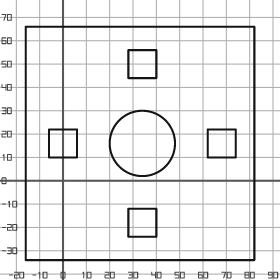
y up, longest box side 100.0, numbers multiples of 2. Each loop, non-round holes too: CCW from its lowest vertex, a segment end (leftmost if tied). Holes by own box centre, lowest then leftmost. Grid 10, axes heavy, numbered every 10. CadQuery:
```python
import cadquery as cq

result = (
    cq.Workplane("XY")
    .moveTo(-16.0, -34.0)
    .lineTo(82.0, -34.0)
    .lineTo(82.0, 66.0)
    .lineTo(-16.0, 66.0)
    .close()
    .moveTo(28.0, -24.0)
    .lineTo(40.0, -24.0)
    .lineTo(40.0, -12.0)
    .lineTo(28.0, -12.0)
    .close()
    .moveTo(-6.0, 10.0)
    .lineTo(6.0, 10.0)
    .lineTo(6.0, 22.0)
    .lineTo(-6.0, 22.0)
    .close()
    .moveTo(34.0, 16.0)
    .circle(14.0)
    .moveTo(62.0, 10.0)
    .lineTo(74.0, 10.0)
    .lineTo(74.0, 22.0)
    .lineTo(62.0, 22.0)
    .close()
    .moveTo(28.0, 44.0)
    .lineTo(40.0, 44.0)
    .lineTo(40.0, 56.0)
    .lineTo(28.0, 56.0)
    .close()
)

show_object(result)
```